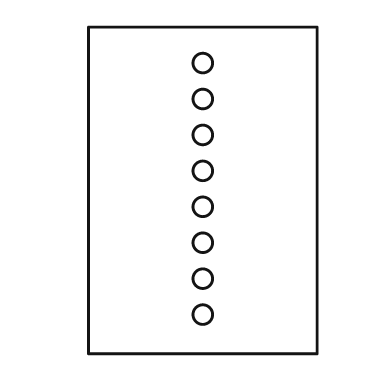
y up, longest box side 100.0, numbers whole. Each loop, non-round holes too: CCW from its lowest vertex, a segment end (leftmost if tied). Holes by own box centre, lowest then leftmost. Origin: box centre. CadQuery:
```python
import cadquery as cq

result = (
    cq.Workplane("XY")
    .moveTo(-35.0, -50.0)
    .lineTo(35.0, -50.0)
    .lineTo(35.0, 50.0)
    .lineTo(-35.0, 50.0)
    .close()
    .moveTo(0.0, -38.0)
    .circle(3.0)
    .moveTo(0.0, -27.0)
    .circle(3.0)
    .moveTo(0.0, -16.0)
    .circle(3.0)
    .moveTo(0.0, -5.0)
    .circle(3.0)
    .moveTo(0.0, 6.0)
    .circle(3.0)
    .moveTo(0.0, 17.0)
    .circle(3.0)
    .moveTo(0.0, 28.0)
    .circle(3.0)
    .moveTo(0.0, 39.0)
    .circle(3.0)
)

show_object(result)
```